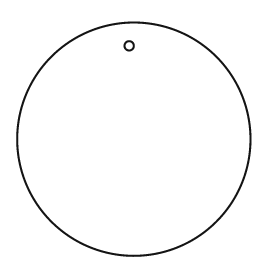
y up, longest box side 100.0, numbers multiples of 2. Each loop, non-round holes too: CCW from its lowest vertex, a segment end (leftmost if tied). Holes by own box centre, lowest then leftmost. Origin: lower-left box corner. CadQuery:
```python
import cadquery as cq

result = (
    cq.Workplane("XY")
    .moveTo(50.0, 50.0)
    .circle(50.0)
    .moveTo(48.0, 90.0)
    .circle(2.0)
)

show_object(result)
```